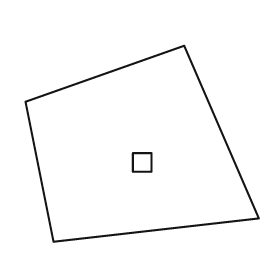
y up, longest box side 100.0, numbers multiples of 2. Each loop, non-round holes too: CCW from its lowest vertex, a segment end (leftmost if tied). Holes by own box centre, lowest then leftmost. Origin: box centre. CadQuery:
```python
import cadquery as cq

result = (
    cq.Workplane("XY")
    .moveTo(-38.0, -42.0)
    .lineTo(50.0, -32.0)
    .lineTo(18.0, 42.0)
    .lineTo(-50.0, 18.0)
    .close()
    .moveTo(-4.0, -12.0)
    .lineTo(4.0, -12.0)
    .lineTo(4.0, -4.0)
    .lineTo(-4.0, -4.0)
    .close()
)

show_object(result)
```